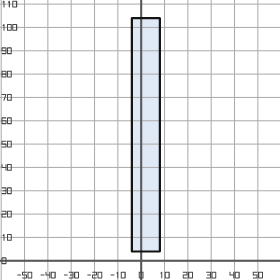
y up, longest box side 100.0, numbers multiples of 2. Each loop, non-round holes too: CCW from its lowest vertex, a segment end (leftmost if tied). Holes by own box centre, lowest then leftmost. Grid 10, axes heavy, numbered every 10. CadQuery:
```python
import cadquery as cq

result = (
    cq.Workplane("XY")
    .moveTo(-4.0, 4.0)
    .lineTo(8.0, 4.0)
    .lineTo(8.0, 104.0)
    .lineTo(-4.0, 104.0)
    .close()
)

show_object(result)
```